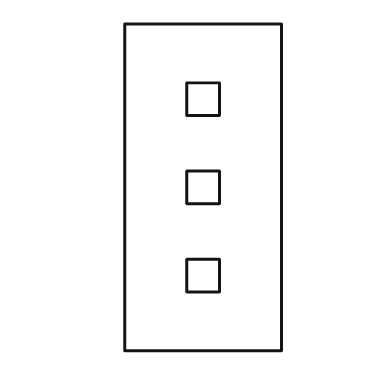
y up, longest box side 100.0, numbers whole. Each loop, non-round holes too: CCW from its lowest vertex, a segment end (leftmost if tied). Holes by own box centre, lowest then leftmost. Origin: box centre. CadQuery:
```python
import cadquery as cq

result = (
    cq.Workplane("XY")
    .moveTo(-24.0, -50.0)
    .lineTo(24.0, -50.0)
    .lineTo(24.0, 50.0)
    .lineTo(-24.0, 50.0)
    .close()
    .moveTo(-5.0, -32.0)
    .lineTo(5.0, -32.0)
    .lineTo(5.0, -22.0)
    .lineTo(-5.0, -22.0)
    .close()
    .moveTo(-5.0, -5.0)
    .lineTo(5.0, -5.0)
    .lineTo(5.0, 5.0)
    .lineTo(-5.0, 5.0)
    .close()
    .moveTo(-5.0, 22.0)
    .lineTo(5.0, 22.0)
    .lineTo(5.0, 32.0)
    .lineTo(-5.0, 32.0)
    .close()
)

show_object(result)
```